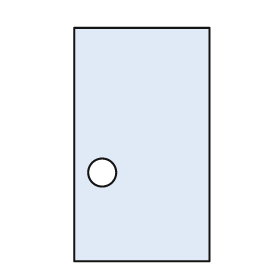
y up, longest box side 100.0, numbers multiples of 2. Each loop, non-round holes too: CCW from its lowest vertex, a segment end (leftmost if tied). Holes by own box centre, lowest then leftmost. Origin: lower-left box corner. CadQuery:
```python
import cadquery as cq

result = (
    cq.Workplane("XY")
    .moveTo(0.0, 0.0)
    .lineTo(58.0, 0.0)
    .lineTo(58.0, 100.0)
    .lineTo(0.0, 100.0)
    .close()
    .moveTo(12.0, 38.0)
    .circle(6.0)
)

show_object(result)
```